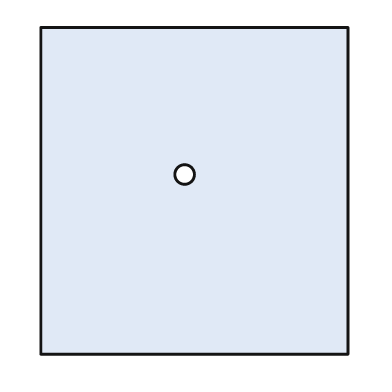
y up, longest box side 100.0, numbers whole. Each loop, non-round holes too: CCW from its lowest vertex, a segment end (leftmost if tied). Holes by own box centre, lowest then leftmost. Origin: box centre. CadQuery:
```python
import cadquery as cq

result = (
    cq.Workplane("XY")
    .moveTo(-47.0, -50.0)
    .lineTo(47.0, -50.0)
    .lineTo(47.0, 50.0)
    .lineTo(-47.0, 50.0)
    .close()
    .moveTo(-3.0, 5.0)
    .circle(3.0)
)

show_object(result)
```